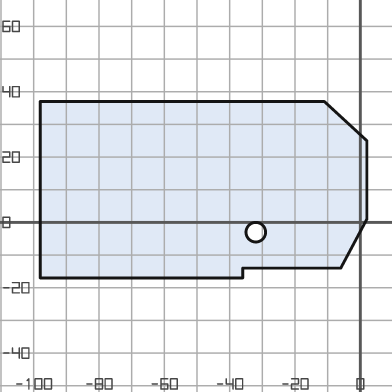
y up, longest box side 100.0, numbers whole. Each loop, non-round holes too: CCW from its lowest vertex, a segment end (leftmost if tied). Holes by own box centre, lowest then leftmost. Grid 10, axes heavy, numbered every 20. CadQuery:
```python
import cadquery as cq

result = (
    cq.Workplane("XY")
    .moveTo(-98.0, -17.0)
    .lineTo(-36.0, -17.0)
    .lineTo(-36.0, -14.0)
    .lineTo(-6.0, -14.0)
    .lineTo(2.0, 1.0)
    .lineTo(2.0, 25.0)
    .lineTo(-11.0, 37.0)
    .lineTo(-98.0, 37.0)
    .close()
    .moveTo(-32.0, -3.0)
    .circle(3.0)
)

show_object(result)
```